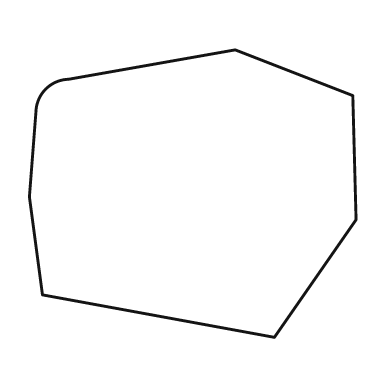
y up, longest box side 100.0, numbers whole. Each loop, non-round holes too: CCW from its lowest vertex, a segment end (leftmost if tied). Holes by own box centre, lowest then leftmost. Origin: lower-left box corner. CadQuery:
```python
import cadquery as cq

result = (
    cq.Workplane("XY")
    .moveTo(75.0, 0.0)
    .lineTo(100.0, 36.0)
    .lineTo(99.0, 74.0)
    .lineTo(63.0, 88.0)
    .lineTo(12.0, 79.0)
    .threePointArc((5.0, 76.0), (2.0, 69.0))
    .lineTo(0.0, 43.0)
    .lineTo(4.0, 13.0)
    .close()
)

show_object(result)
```